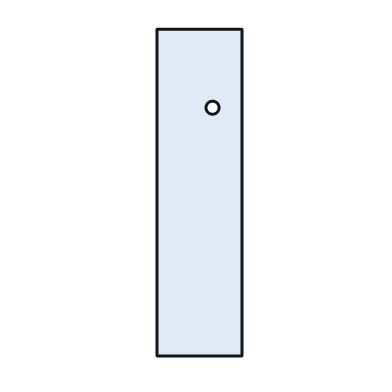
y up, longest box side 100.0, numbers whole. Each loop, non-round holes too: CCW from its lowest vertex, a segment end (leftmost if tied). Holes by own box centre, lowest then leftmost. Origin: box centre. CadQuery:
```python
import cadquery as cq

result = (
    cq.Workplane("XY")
    .moveTo(-13.0, -50.0)
    .lineTo(13.0, -50.0)
    .lineTo(13.0, 50.0)
    .lineTo(-13.0, 50.0)
    .close()
    .moveTo(4.0, 26.0)
    .circle(2.0)
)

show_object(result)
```